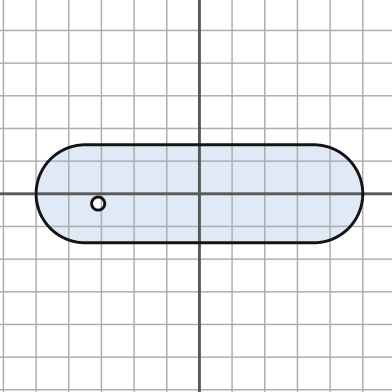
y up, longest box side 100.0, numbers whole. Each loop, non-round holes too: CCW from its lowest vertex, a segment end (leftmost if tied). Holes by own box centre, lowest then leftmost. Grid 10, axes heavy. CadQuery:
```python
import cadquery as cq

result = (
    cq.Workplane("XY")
    .moveTo(-35.0, -15.0)
    .lineTo(35.0, -15.0)
    .threePointArc((50.0, 0.0), (35.0, 15.0))
    .lineTo(-35.0, 15.0)
    .threePointArc((-50.0, 0.0), (-35.0, -15.0))
    .close()
    .moveTo(-31.0, -3.0)
    .circle(2.0)
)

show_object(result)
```